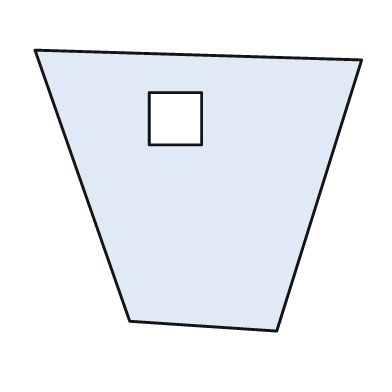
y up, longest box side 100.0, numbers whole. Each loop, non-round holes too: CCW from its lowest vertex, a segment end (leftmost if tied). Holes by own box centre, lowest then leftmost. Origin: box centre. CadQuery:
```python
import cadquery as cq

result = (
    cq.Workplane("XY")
    .moveTo(24.0, -43.0)
    .lineTo(50.0, 40.0)
    .lineTo(-50.0, 43.0)
    .lineTo(-21.0, -40.0)
    .close()
    .moveTo(-15.0, 14.0)
    .lineTo(1.0, 14.0)
    .lineTo(1.0, 30.0)
    .lineTo(-15.0, 30.0)
    .close()
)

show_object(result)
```